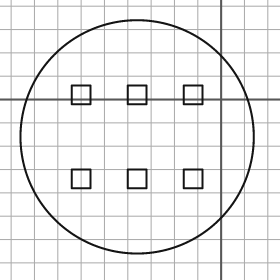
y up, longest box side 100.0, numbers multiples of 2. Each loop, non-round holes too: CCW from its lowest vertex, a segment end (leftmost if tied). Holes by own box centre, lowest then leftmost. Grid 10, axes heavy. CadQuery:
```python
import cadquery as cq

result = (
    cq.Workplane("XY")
    .moveTo(-36.0, -16.0)
    .circle(50.0)
    .moveTo(-64.0, -38.0)
    .lineTo(-56.0, -38.0)
    .lineTo(-56.0, -30.0)
    .lineTo(-64.0, -30.0)
    .close()
    .moveTo(-40.0, -38.0)
    .lineTo(-32.0, -38.0)
    .lineTo(-32.0, -30.0)
    .lineTo(-40.0, -30.0)
    .close()
    .moveTo(-16.0, -38.0)
    .lineTo(-8.0, -38.0)
    .lineTo(-8.0, -30.0)
    .lineTo(-16.0, -30.0)
    .close()
    .moveTo(-64.0, -2.0)
    .lineTo(-56.0, -2.0)
    .lineTo(-56.0, 6.0)
    .lineTo(-64.0, 6.0)
    .close()
    .moveTo(-40.0, -2.0)
    .lineTo(-32.0, -2.0)
    .lineTo(-32.0, 6.0)
    .lineTo(-40.0, 6.0)
    .close()
    .moveTo(-16.0, -2.0)
    .lineTo(-8.0, -2.0)
    .lineTo(-8.0, 6.0)
    .lineTo(-16.0, 6.0)
    .close()
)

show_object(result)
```